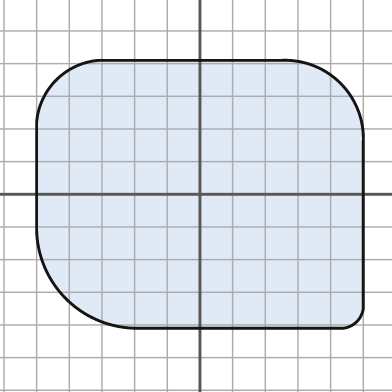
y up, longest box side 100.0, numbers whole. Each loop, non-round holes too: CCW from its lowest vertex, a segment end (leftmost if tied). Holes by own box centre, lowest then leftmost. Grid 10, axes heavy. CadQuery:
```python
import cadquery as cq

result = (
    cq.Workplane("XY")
    .moveTo(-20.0, -41.0)
    .lineTo(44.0, -41.0)
    .threePointArc((48.0, -39.0), (50.0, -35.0))
    .lineTo(50.0, 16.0)
    .threePointArc((43.0, 34.0), (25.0, 41.0))
    .lineTo(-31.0, 41.0)
    .threePointArc((-44.0, 35.0), (-50.0, 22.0))
    .lineTo(-50.0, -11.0)
    .threePointArc((-41.0, -32.0), (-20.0, -41.0))
    .close()
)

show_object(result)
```